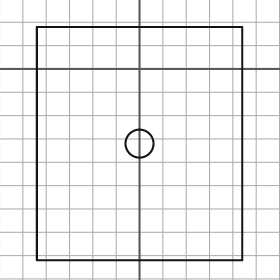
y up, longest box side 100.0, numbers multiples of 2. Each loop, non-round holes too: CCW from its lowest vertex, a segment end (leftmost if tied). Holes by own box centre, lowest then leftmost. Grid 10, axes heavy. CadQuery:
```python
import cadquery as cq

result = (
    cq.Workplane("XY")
    .moveTo(-44.0, -82.0)
    .lineTo(44.0, -82.0)
    .lineTo(44.0, 18.0)
    .lineTo(-44.0, 18.0)
    .close()
    .moveTo(0.0, -32.0)
    .circle(6.0)
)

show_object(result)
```